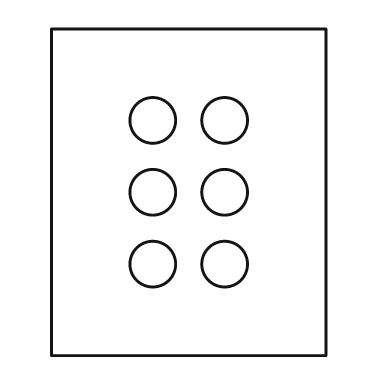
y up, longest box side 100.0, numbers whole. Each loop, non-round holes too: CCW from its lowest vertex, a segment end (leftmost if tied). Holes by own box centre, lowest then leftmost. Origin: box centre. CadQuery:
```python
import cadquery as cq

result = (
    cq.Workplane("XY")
    .moveTo(-42.0, -50.0)
    .lineTo(42.0, -50.0)
    .lineTo(42.0, 50.0)
    .lineTo(-42.0, 50.0)
    .close()
    .moveTo(-11.0, -22.0)
    .circle(7.0)
    .moveTo(11.0, -22.0)
    .circle(7.0)
    .moveTo(-11.0, 0.0)
    .circle(7.0)
    .moveTo(11.0, 0.0)
    .circle(7.0)
    .moveTo(-11.0, 22.0)
    .circle(7.0)
    .moveTo(11.0, 22.0)
    .circle(7.0)
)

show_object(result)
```